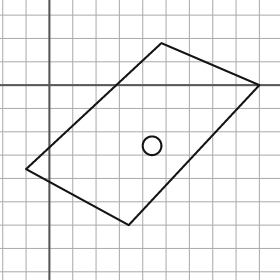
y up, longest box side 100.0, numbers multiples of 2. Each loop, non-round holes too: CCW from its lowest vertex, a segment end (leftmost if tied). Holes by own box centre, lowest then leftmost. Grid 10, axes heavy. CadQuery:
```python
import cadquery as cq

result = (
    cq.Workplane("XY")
    .moveTo(34.0, -60.0)
    .lineTo(90.0, 0.0)
    .lineTo(48.0, 18.0)
    .lineTo(-10.0, -36.0)
    .close()
    .moveTo(44.0, -26.0)
    .circle(4.0)
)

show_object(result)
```